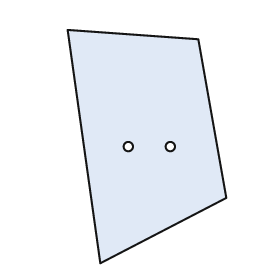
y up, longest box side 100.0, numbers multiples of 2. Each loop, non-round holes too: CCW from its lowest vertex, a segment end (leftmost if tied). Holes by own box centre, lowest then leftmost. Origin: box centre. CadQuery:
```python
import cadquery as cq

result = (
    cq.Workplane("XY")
    .moveTo(-20.0, -50.0)
    .lineTo(34.0, -22.0)
    .lineTo(22.0, 46.0)
    .lineTo(-34.0, 50.0)
    .close()
    .moveTo(-8.0, 0.0)
    .circle(2.0)
    .moveTo(10.0, 0.0)
    .circle(2.0)
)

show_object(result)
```